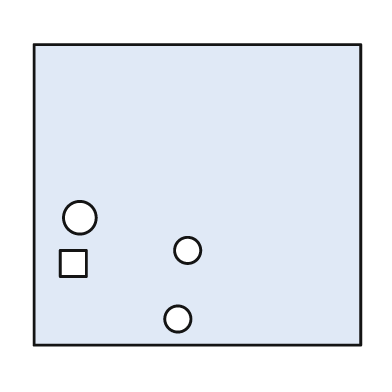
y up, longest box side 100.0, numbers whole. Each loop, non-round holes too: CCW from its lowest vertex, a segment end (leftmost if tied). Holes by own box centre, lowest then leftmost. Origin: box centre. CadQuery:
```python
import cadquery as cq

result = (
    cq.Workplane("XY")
    .moveTo(-50.0, -46.0)
    .lineTo(50.0, -46.0)
    .lineTo(50.0, 46.0)
    .lineTo(-50.0, 46.0)
    .close()
    .moveTo(-6.0, -38.0)
    .circle(4.0)
    .moveTo(-42.0, -25.0)
    .lineTo(-34.0, -25.0)
    .lineTo(-34.0, -17.0)
    .lineTo(-42.0, -17.0)
    .close()
    .moveTo(-3.0, -17.0)
    .circle(4.0)
    .moveTo(-36.0, -7.0)
    .circle(5.0)
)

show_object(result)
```